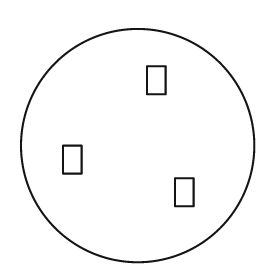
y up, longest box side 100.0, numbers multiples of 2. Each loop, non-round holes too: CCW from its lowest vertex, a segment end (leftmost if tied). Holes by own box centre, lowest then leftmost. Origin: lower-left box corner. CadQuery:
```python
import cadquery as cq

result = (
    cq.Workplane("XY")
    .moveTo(50.0, 50.0)
    .circle(50.0)
    .moveTo(66.0, 24.0)
    .lineTo(74.0, 24.0)
    .lineTo(74.0, 36.0)
    .lineTo(66.0, 36.0)
    .close()
    .moveTo(18.0, 38.0)
    .lineTo(26.0, 38.0)
    .lineTo(26.0, 50.0)
    .lineTo(18.0, 50.0)
    .close()
    .moveTo(54.0, 72.0)
    .lineTo(62.0, 72.0)
    .lineTo(62.0, 84.0)
    .lineTo(54.0, 84.0)
    .close()
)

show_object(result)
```